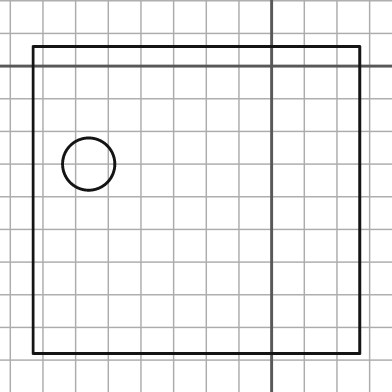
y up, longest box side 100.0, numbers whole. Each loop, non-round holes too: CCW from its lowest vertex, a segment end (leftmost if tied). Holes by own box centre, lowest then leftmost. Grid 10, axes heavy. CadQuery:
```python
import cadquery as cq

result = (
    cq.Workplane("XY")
    .moveTo(-73.0, -88.0)
    .lineTo(27.0, -88.0)
    .lineTo(27.0, 6.0)
    .lineTo(-73.0, 6.0)
    .close()
    .moveTo(-56.0, -30.0)
    .circle(8.0)
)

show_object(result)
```